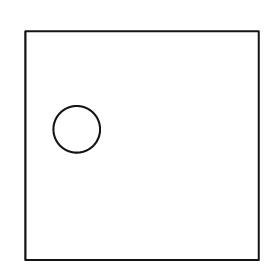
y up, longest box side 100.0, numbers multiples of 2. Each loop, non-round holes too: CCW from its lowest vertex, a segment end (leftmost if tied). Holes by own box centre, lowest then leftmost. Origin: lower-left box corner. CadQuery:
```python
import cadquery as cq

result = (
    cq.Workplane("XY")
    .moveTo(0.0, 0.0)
    .lineTo(100.0, 0.0)
    .lineTo(100.0, 98.0)
    .lineTo(0.0, 98.0)
    .close()
    .moveTo(22.0, 56.0)
    .circle(10.0)
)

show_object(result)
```